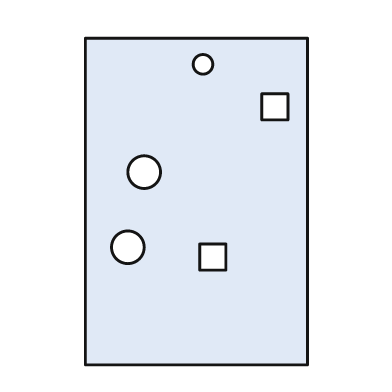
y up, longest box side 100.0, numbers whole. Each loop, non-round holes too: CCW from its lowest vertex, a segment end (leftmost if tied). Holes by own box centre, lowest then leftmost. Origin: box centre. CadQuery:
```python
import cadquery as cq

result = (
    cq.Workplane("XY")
    .moveTo(-34.0, -50.0)
    .lineTo(34.0, -50.0)
    .lineTo(34.0, 50.0)
    .lineTo(-34.0, 50.0)
    .close()
    .moveTo(1.0, -21.0)
    .lineTo(9.0, -21.0)
    .lineTo(9.0, -13.0)
    .lineTo(1.0, -13.0)
    .close()
    .moveTo(-21.0, -14.0)
    .circle(5.0)
    .moveTo(-16.0, 9.0)
    .circle(5.0)
    .moveTo(20.0, 25.0)
    .lineTo(28.0, 25.0)
    .lineTo(28.0, 33.0)
    .lineTo(20.0, 33.0)
    .close()
    .moveTo(2.0, 42.0)
    .circle(3.0)
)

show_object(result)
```